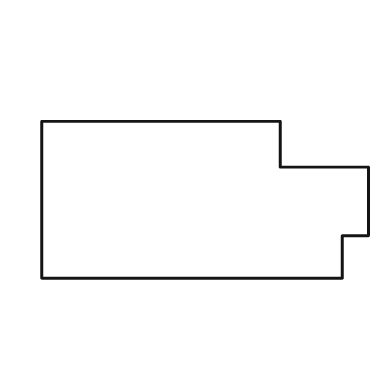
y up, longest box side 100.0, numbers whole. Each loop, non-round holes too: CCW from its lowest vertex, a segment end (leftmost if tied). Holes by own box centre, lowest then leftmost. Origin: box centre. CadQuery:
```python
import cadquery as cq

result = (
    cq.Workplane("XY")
    .moveTo(-50.0, -24.0)
    .lineTo(42.0, -24.0)
    .lineTo(42.0, -11.0)
    .lineTo(50.0, -11.0)
    .lineTo(50.0, 10.0)
    .lineTo(23.0, 10.0)
    .lineTo(23.0, 24.0)
    .lineTo(-50.0, 24.0)
    .close()
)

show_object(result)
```